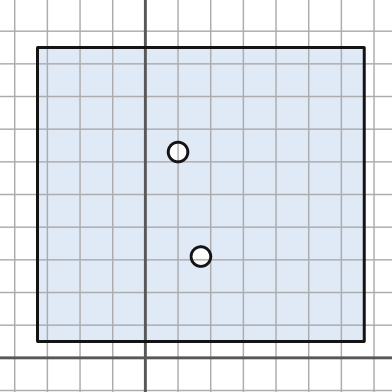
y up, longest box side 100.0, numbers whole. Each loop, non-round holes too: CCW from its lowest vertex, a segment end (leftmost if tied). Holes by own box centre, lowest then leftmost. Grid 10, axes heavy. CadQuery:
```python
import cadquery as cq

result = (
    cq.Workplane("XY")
    .moveTo(-33.0, 5.0)
    .lineTo(67.0, 5.0)
    .lineTo(67.0, 95.0)
    .lineTo(-33.0, 95.0)
    .close()
    .moveTo(17.0, 31.0)
    .circle(3.0)
    .moveTo(10.0, 63.0)
    .circle(3.0)
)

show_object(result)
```